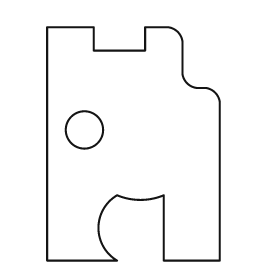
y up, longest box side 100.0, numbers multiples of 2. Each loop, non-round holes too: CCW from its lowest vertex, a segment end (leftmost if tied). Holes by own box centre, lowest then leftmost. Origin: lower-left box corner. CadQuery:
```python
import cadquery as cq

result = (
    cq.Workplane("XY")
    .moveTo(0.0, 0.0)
    .lineTo(30.0, 0.0)
    .threePointArc((22.0, 14.0), (30.0, 28.0))
    .threePointArc((40.0, 26.0), (50.0, 28.0))
    .lineTo(50.0, 0.0)
    .lineTo(74.0, 0.0)
    .lineTo(74.0, 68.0)
    .threePointArc((72.0, 72.0), (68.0, 74.0))
    .lineTo(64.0, 74.0)
    .threePointArc((60.0, 76.0), (58.0, 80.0))
    .lineTo(58.0, 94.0)
    .threePointArc((56.0, 98.0), (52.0, 100.0))
    .lineTo(42.0, 100.0)
    .lineTo(42.0, 90.0)
    .lineTo(20.0, 90.0)
    .lineTo(20.0, 100.0)
    .lineTo(0.0, 100.0)
    .close()
    .moveTo(16.0, 56.0)
    .circle(8.0)
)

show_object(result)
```